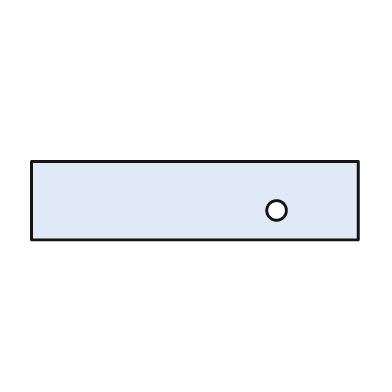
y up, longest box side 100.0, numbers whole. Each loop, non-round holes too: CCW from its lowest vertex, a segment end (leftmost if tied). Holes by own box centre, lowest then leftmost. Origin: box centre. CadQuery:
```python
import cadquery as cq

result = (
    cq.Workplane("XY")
    .moveTo(-50.0, -12.0)
    .lineTo(50.0, -12.0)
    .lineTo(50.0, 12.0)
    .lineTo(-50.0, 12.0)
    .close()
    .moveTo(25.0, -3.0)
    .circle(3.0)
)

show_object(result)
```